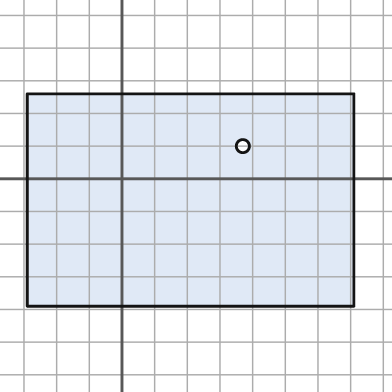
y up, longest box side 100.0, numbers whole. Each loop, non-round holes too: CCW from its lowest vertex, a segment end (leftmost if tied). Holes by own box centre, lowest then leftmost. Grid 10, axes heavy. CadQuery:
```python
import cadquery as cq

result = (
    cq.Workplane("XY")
    .moveTo(-29.0, -39.0)
    .lineTo(71.0, -39.0)
    .lineTo(71.0, 26.0)
    .lineTo(-29.0, 26.0)
    .close()
    .moveTo(37.0, 10.0)
    .circle(2.0)
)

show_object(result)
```